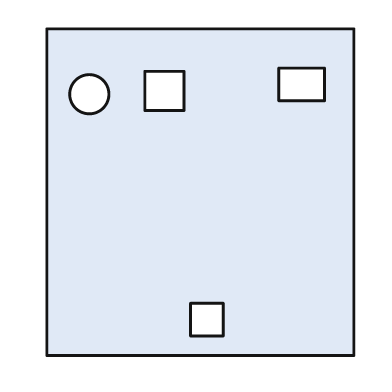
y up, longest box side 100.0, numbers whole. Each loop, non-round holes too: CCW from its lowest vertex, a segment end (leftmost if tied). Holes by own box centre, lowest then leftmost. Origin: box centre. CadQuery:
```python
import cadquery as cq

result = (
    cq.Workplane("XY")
    .moveTo(-47.0, -50.0)
    .lineTo(47.0, -50.0)
    .lineTo(47.0, 50.0)
    .lineTo(-47.0, 50.0)
    .close()
    .moveTo(-3.0, -44.0)
    .lineTo(7.0, -44.0)
    .lineTo(7.0, -34.0)
    .lineTo(-3.0, -34.0)
    .close()
    .moveTo(-34.0, 30.0)
    .circle(6.0)
    .moveTo(-17.0, 25.0)
    .lineTo(-5.0, 25.0)
    .lineTo(-5.0, 37.0)
    .lineTo(-17.0, 37.0)
    .close()
    .moveTo(24.0, 28.0)
    .lineTo(38.0, 28.0)
    .lineTo(38.0, 38.0)
    .lineTo(24.0, 38.0)
    .close()
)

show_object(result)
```